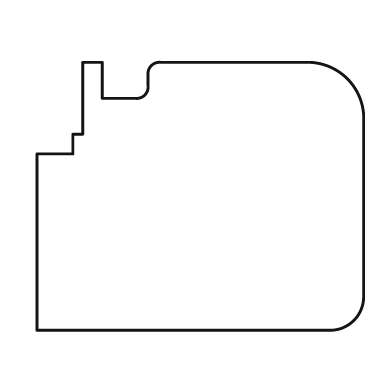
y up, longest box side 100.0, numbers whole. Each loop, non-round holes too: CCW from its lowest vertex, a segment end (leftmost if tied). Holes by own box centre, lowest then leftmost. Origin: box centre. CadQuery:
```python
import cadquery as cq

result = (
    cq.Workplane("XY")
    .moveTo(-50.0, -41.0)
    .lineTo(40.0, -41.0)
    .threePointArc((47.0, -38.0), (50.0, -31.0))
    .lineTo(50.0, 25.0)
    .threePointArc((45.0, 36.0), (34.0, 41.0))
    .lineTo(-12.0, 41.0)
    .threePointArc((-15.0, 40.0), (-16.0, 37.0))
    .lineTo(-16.0, 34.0)
    .threePointArc((-17.0, 31.0), (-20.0, 30.0))
    .lineTo(-30.0, 30.0)
    .lineTo(-30.0, 41.0)
    .lineTo(-36.0, 41.0)
    .lineTo(-36.0, 19.0)
    .lineTo(-39.0, 19.0)
    .lineTo(-39.0, 13.0)
    .lineTo(-50.0, 13.0)
    .close()
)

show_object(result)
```